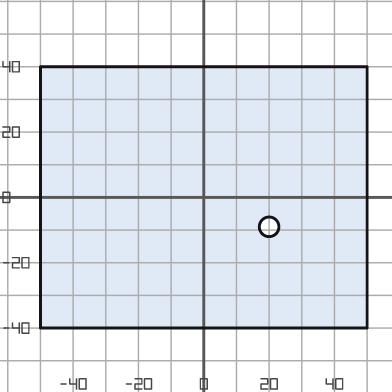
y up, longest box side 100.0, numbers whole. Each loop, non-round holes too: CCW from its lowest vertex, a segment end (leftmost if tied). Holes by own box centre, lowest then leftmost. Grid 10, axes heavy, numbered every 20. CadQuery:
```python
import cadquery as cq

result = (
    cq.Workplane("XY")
    .moveTo(-50.0, -40.0)
    .lineTo(50.0, -40.0)
    .lineTo(50.0, 40.0)
    .lineTo(-50.0, 40.0)
    .close()
    .moveTo(20.0, -9.0)
    .circle(3.0)
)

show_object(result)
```